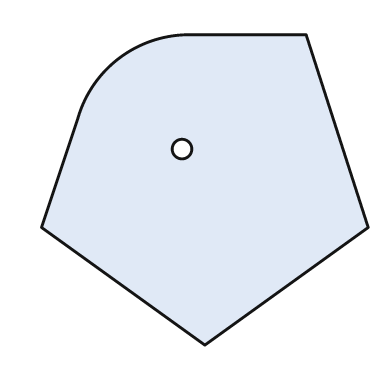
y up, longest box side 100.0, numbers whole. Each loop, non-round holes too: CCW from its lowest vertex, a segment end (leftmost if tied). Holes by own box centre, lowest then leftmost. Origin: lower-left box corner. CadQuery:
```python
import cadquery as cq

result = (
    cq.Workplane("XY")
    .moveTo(50.0, 0.0)
    .lineTo(100.0, 36.0)
    .lineTo(81.0, 95.0)
    .lineTo(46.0, 95.0)
    .threePointArc((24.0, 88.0), (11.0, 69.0))
    .lineTo(0.0, 36.0)
    .close()
    .moveTo(43.0, 60.0)
    .circle(3.0)
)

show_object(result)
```